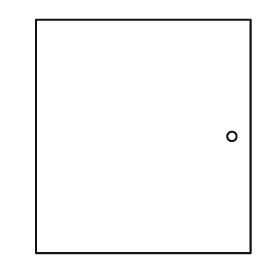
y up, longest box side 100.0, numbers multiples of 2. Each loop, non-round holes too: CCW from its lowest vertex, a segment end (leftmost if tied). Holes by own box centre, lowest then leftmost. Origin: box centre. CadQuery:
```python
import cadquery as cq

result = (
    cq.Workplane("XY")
    .moveTo(-46.0, -50.0)
    .lineTo(46.0, -50.0)
    .lineTo(46.0, 50.0)
    .lineTo(-46.0, 50.0)
    .close()
    .moveTo(38.0, 0.0)
    .circle(2.0)
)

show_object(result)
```